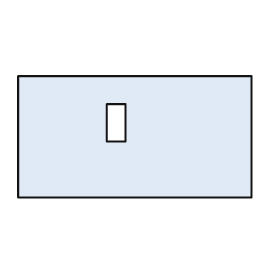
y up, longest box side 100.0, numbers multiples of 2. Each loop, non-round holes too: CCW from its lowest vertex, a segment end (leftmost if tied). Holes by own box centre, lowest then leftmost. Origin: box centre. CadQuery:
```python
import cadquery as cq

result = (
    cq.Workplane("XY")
    .moveTo(-50.0, -26.0)
    .lineTo(50.0, -26.0)
    .lineTo(50.0, 26.0)
    .lineTo(-50.0, 26.0)
    .close()
    .moveTo(-12.0, -2.0)
    .lineTo(-4.0, -2.0)
    .lineTo(-4.0, 14.0)
    .lineTo(-12.0, 14.0)
    .close()
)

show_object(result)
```